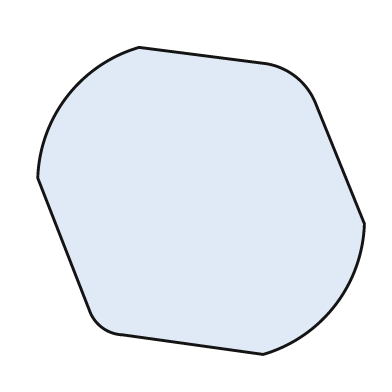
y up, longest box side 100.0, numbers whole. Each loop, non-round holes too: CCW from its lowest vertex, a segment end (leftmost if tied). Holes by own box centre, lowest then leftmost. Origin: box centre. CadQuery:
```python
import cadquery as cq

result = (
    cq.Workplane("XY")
    .moveTo(19.0, -47.0)
    .threePointArc((41.0, -32.0), (50.0, -7.0))
    .lineTo(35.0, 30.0)
    .threePointArc((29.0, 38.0), (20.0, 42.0))
    .lineTo(-19.0, 47.0)
    .threePointArc((-41.0, 32.0), (-50.0, 7.0))
    .lineTo(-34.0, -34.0)
    .threePointArc((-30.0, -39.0), (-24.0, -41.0))
    .close()
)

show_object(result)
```